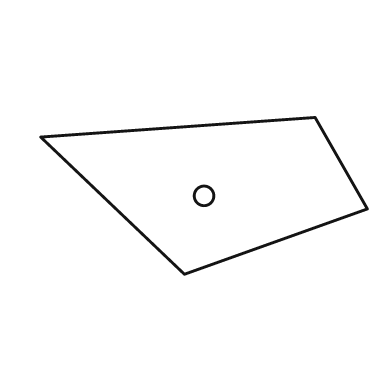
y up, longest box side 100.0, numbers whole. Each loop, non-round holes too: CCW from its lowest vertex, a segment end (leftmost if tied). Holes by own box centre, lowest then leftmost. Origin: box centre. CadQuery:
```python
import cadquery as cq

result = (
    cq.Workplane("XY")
    .moveTo(-6.0, -24.0)
    .lineTo(50.0, -4.0)
    .lineTo(34.0, 24.0)
    .lineTo(-50.0, 18.0)
    .close()
    .moveTo(0.0, 0.0)
    .circle(3.0)
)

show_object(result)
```